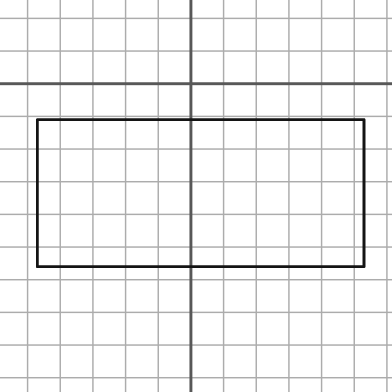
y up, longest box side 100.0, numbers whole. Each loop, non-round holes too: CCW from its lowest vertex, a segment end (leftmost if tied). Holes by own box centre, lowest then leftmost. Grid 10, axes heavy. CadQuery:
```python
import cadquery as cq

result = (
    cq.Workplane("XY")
    .moveTo(-47.0, -56.0)
    .lineTo(53.0, -56.0)
    .lineTo(53.0, -11.0)
    .lineTo(-47.0, -11.0)
    .close()
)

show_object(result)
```